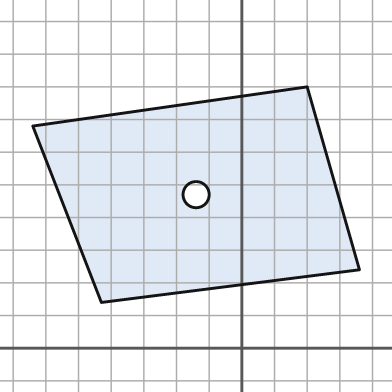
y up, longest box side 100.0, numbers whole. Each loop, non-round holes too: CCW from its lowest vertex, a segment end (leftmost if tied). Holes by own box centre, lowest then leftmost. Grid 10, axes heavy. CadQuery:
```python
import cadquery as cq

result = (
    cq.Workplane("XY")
    .moveTo(-43.0, 14.0)
    .lineTo(36.0, 24.0)
    .lineTo(20.0, 80.0)
    .lineTo(-64.0, 68.0)
    .close()
    .moveTo(-14.0, 47.0)
    .circle(4.0)
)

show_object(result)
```